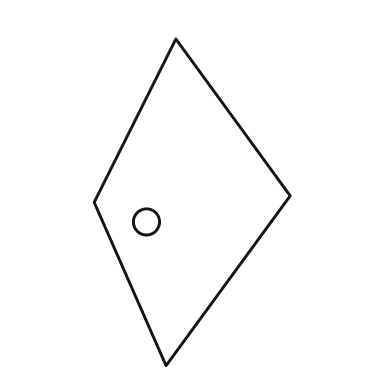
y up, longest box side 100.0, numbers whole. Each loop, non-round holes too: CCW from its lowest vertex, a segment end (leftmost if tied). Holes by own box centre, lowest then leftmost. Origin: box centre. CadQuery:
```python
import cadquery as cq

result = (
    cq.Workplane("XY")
    .moveTo(-8.0, -50.0)
    .lineTo(30.0, 2.0)
    .lineTo(-5.0, 50.0)
    .lineTo(-30.0, 0.0)
    .close()
    .moveTo(-14.0, -6.0)
    .circle(4.0)
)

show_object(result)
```